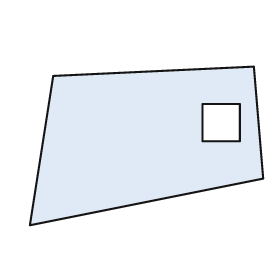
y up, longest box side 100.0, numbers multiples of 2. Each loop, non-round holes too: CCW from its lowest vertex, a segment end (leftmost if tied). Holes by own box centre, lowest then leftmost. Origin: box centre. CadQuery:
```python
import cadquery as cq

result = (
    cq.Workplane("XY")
    .moveTo(-50.0, -34.0)
    .lineTo(50.0, -14.0)
    .lineTo(46.0, 34.0)
    .lineTo(-40.0, 30.0)
    .close()
    .moveTo(24.0, 2.0)
    .lineTo(40.0, 2.0)
    .lineTo(40.0, 18.0)
    .lineTo(24.0, 18.0)
    .close()
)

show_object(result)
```